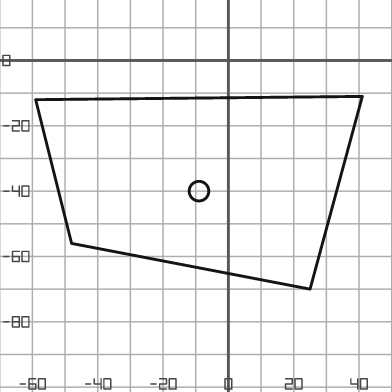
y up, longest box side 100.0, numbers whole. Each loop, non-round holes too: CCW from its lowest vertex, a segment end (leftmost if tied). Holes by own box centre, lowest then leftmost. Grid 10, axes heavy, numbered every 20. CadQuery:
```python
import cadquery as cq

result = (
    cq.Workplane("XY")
    .moveTo(25.0, -70.0)
    .lineTo(41.0, -11.0)
    .lineTo(-59.0, -12.0)
    .lineTo(-48.0, -56.0)
    .close()
    .moveTo(-9.0, -40.0)
    .circle(3.0)
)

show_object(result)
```